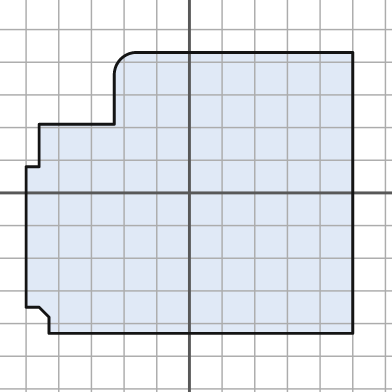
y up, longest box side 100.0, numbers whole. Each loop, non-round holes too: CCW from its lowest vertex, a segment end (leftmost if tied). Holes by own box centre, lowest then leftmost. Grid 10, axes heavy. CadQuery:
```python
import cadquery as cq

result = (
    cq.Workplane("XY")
    .moveTo(-43.0, -43.0)
    .lineTo(50.0, -43.0)
    .lineTo(50.0, 43.0)
    .lineTo(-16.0, 43.0)
    .threePointArc((-21.0, 41.0), (-23.0, 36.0))
    .lineTo(-23.0, 21.0)
    .lineTo(-46.0, 21.0)
    .lineTo(-46.0, 8.0)
    .lineTo(-50.0, 8.0)
    .lineTo(-50.0, -35.0)
    .lineTo(-46.0, -35.0)
    .lineTo(-43.0, -38.0)
    .close()
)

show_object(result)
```